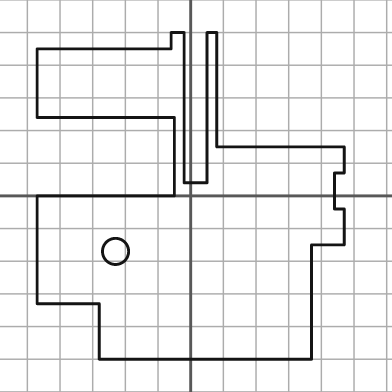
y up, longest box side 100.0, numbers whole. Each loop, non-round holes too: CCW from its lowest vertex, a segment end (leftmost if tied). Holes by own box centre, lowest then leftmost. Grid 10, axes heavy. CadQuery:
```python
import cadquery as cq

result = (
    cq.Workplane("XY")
    .moveTo(-28.0, -50.0)
    .lineTo(37.0, -50.0)
    .lineTo(37.0, -15.0)
    .lineTo(47.0, -15.0)
    .lineTo(47.0, -4.0)
    .lineTo(44.0, -4.0)
    .lineTo(44.0, 7.0)
    .lineTo(47.0, 7.0)
    .lineTo(47.0, 15.0)
    .lineTo(8.0, 15.0)
    .lineTo(8.0, 50.0)
    .lineTo(5.0, 50.0)
    .lineTo(5.0, 4.0)
    .lineTo(-2.0, 4.0)
    .lineTo(-2.0, 50.0)
    .lineTo(-6.0, 50.0)
    .lineTo(-6.0, 45.0)
    .lineTo(-47.0, 45.0)
    .lineTo(-47.0, 24.0)
    .lineTo(-5.0, 24.0)
    .lineTo(-5.0, 0.0)
    .lineTo(-47.0, 0.0)
    .lineTo(-47.0, -33.0)
    .lineTo(-28.0, -33.0)
    .close()
    .moveTo(-23.0, -17.0)
    .circle(4.0)
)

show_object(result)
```